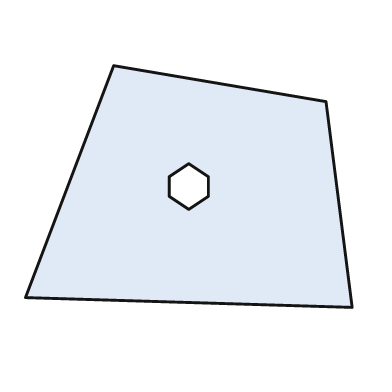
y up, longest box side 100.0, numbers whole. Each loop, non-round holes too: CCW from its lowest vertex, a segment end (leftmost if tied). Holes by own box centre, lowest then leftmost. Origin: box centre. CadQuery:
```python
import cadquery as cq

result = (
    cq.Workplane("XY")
    .moveTo(50.0, -37.0)
    .lineTo(42.0, 26.0)
    .lineTo(-23.0, 37.0)
    .lineTo(-50.0, -34.0)
    .close()
    .moveTo(0.0, -7.0)
    .lineTo(6.0, -3.0)
    .lineTo(6.0, 3.0)
    .lineTo(0.0, 7.0)
    .lineTo(-6.0, 3.0)
    .lineTo(-6.0, -3.0)
    .close()
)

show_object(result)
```